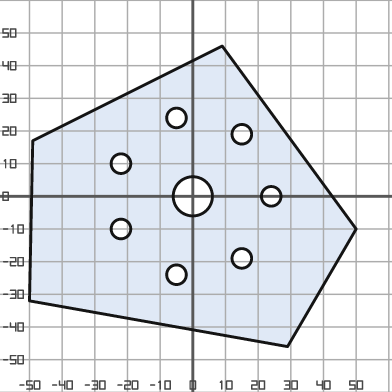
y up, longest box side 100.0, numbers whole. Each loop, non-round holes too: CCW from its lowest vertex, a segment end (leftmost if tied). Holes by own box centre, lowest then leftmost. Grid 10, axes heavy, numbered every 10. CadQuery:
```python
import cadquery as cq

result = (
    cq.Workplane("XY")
    .moveTo(29.0, -46.0)
    .lineTo(50.0, -10.0)
    .lineTo(9.0, 46.0)
    .lineTo(-49.0, 17.0)
    .lineTo(-50.0, -32.0)
    .close()
    .moveTo(-5.0, -24.0)
    .circle(3.0)
    .moveTo(15.0, -19.0)
    .circle(3.0)
    .moveTo(-22.0, -10.0)
    .circle(3.0)
    .moveTo(0.0, 0.0)
    .circle(6.0)
    .moveTo(24.0, 0.0)
    .circle(3.0)
    .moveTo(-22.0, 10.0)
    .circle(3.0)
    .moveTo(15.0, 19.0)
    .circle(3.0)
    .moveTo(-5.0, 24.0)
    .circle(3.0)
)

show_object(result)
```